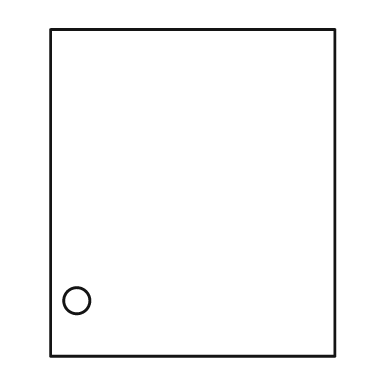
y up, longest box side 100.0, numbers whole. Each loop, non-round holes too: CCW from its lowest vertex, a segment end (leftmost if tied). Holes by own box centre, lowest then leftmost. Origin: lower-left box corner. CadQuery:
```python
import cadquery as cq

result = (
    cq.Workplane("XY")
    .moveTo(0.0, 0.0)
    .lineTo(87.0, 0.0)
    .lineTo(87.0, 100.0)
    .lineTo(0.0, 100.0)
    .close()
    .moveTo(8.0, 17.0)
    .circle(4.0)
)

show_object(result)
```